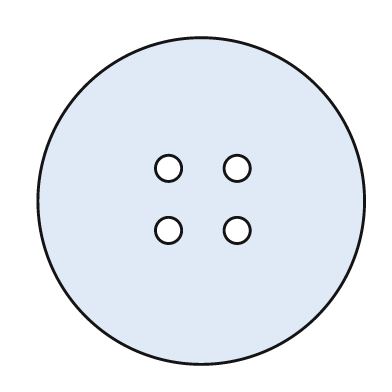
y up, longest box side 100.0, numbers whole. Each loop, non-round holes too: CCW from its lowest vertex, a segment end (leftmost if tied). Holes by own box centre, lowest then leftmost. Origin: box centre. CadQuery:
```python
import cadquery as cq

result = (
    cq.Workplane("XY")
    .moveTo(0.0, 0.0)
    .circle(50.0)
    .moveTo(-10.0, -9.0)
    .circle(4.0)
    .moveTo(11.0, -9.0)
    .circle(4.0)
    .moveTo(-10.0, 10.0)
    .circle(4.0)
    .moveTo(11.0, 10.0)
    .circle(4.0)
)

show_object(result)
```